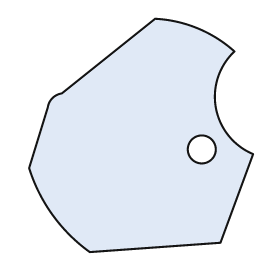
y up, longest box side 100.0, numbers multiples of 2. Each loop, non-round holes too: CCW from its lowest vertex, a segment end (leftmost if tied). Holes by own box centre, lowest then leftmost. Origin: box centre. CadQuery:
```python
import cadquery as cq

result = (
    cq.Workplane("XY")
    .moveTo(-22.0, -50.0)
    .lineTo(34.0, -46.0)
    .lineTo(48.0, -8.0)
    .threePointArc((32.0, 12.0), (40.0, 36.0))
    .threePointArc((24.0, 46.0), (6.0, 50.0))
    .lineTo(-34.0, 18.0)
    .threePointArc((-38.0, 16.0), (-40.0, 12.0))
    .lineTo(-48.0, -14.0)
    .threePointArc((-38.0, -34.0), (-22.0, -50.0))
    .close()
    .moveTo(26.0, -6.0)
    .circle(6.0)
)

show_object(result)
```